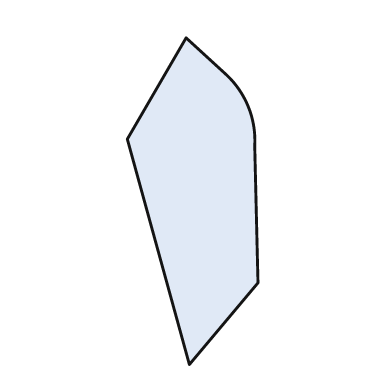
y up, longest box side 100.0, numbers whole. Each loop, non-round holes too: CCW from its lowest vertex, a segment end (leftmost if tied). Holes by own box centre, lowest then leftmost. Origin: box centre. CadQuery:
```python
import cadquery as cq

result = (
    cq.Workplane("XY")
    .moveTo(-1.0, -50.0)
    .lineTo(20.0, -25.0)
    .lineTo(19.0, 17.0)
    .threePointArc((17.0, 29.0), (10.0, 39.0))
    .lineTo(-2.0, 50.0)
    .lineTo(-20.0, 19.0)
    .close()
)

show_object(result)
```